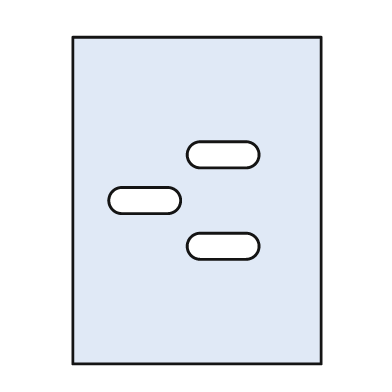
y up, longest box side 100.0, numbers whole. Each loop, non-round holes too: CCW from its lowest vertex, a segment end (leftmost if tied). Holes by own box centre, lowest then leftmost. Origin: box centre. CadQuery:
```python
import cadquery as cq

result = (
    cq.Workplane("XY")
    .moveTo(-38.0, -50.0)
    .lineTo(38.0, -50.0)
    .lineTo(38.0, 50.0)
    .lineTo(-38.0, 50.0)
    .close()
    .moveTo(1.0, -18.0)
    .lineTo(15.0, -18.0)
    .threePointArc((19.0, -14.0), (15.0, -10.0))
    .lineTo(1.0, -10.0)
    .threePointArc((-3.0, -14.0), (1.0, -18.0))
    .close()
    .moveTo(-23.0, -4.0)
    .lineTo(-9.0, -4.0)
    .threePointArc((-5.0, 0.0), (-9.0, 4.0))
    .lineTo(-23.0, 4.0)
    .threePointArc((-27.0, 0.0), (-23.0, -4.0))
    .close()
    .moveTo(1.0, 10.0)
    .lineTo(15.0, 10.0)
    .threePointArc((19.0, 14.0), (15.0, 18.0))
    .lineTo(1.0, 18.0)
    .threePointArc((-3.0, 14.0), (1.0, 10.0))
    .close()
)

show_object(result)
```